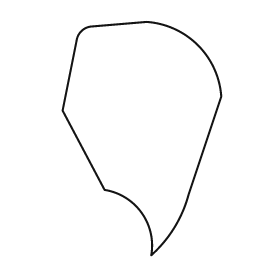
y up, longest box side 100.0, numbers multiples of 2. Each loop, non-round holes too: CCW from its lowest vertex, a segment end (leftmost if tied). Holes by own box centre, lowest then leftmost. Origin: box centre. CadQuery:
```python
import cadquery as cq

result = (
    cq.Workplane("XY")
    .moveTo(4.0, -50.0)
    .threePointArc((14.0, -38.0), (20.0, -24.0))
    .lineTo(34.0, 18.0)
    .threePointArc((24.0, 40.0), (2.0, 50.0))
    .lineTo(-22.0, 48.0)
    .threePointArc((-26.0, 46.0), (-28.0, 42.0))
    .lineTo(-34.0, 12.0)
    .lineTo(-16.0, -22.0)
    .threePointArc((0.0, -32.0), (4.0, -50.0))
    .close()
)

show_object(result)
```